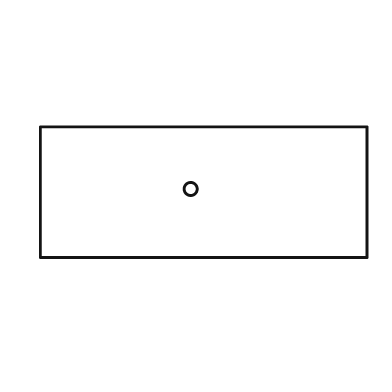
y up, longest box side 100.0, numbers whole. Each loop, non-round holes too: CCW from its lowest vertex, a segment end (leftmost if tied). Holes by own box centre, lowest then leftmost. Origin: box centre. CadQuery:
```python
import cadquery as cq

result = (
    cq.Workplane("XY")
    .moveTo(-50.0, -20.0)
    .lineTo(50.0, -20.0)
    .lineTo(50.0, 20.0)
    .lineTo(-50.0, 20.0)
    .close()
    .moveTo(-4.0, 1.0)
    .circle(2.0)
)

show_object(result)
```